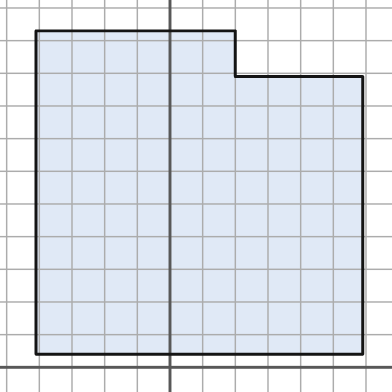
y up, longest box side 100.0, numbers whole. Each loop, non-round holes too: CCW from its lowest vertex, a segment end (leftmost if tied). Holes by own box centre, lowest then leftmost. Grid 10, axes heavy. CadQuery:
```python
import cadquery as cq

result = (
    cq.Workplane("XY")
    .moveTo(-41.0, 4.0)
    .lineTo(59.0, 4.0)
    .lineTo(59.0, 89.0)
    .lineTo(20.0, 89.0)
    .lineTo(20.0, 103.0)
    .lineTo(-41.0, 103.0)
    .close()
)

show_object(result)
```